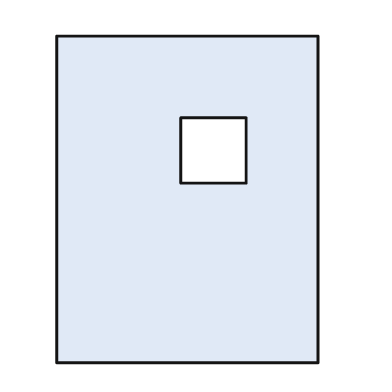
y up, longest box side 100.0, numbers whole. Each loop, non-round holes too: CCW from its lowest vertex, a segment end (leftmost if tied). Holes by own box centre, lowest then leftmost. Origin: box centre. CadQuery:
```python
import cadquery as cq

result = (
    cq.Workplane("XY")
    .moveTo(-40.0, -50.0)
    .lineTo(40.0, -50.0)
    .lineTo(40.0, 50.0)
    .lineTo(-40.0, 50.0)
    .close()
    .moveTo(-2.0, 5.0)
    .lineTo(18.0, 5.0)
    .lineTo(18.0, 25.0)
    .lineTo(-2.0, 25.0)
    .close()
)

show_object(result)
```